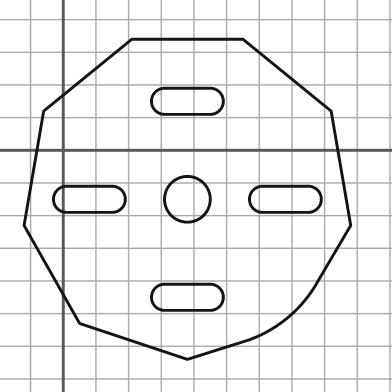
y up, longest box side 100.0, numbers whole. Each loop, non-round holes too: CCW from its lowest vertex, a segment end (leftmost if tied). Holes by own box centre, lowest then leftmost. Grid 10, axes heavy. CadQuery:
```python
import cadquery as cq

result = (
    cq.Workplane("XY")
    .moveTo(38.0, -64.0)
    .lineTo(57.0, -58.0)
    .threePointArc((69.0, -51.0), (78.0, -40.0))
    .lineTo(88.0, -23.0)
    .lineTo(82.0, 12.0)
    .lineTo(55.0, 34.0)
    .lineTo(21.0, 34.0)
    .lineTo(-6.0, 12.0)
    .lineTo(-12.0, -23.0)
    .lineTo(5.0, -53.0)
    .close()
    .moveTo(31.0, -49.0)
    .lineTo(45.0, -49.0)
    .threePointArc((49.0, -45.0), (45.0, -41.0))
    .lineTo(31.0, -41.0)
    .threePointArc((27.0, -45.0), (31.0, -49.0))
    .close()
    .moveTo(1.0, -19.0)
    .lineTo(15.0, -19.0)
    .threePointArc((19.0, -15.0), (15.0, -11.0))
    .lineTo(1.0, -11.0)
    .threePointArc((-3.0, -15.0), (1.0, -19.0))
    .close()
    .moveTo(38.0, -15.0)
    .circle(7.0)
    .moveTo(61.0, -19.0)
    .lineTo(75.0, -19.0)
    .threePointArc((79.0, -15.0), (75.0, -11.0))
    .lineTo(61.0, -11.0)
    .threePointArc((57.0, -15.0), (61.0, -19.0))
    .close()
    .moveTo(31.0, 11.0)
    .lineTo(45.0, 11.0)
    .threePointArc((49.0, 15.0), (45.0, 19.0))
    .lineTo(31.0, 19.0)
    .threePointArc((27.0, 15.0), (31.0, 11.0))
    .close()
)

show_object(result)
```